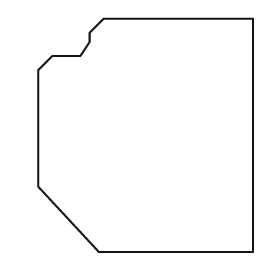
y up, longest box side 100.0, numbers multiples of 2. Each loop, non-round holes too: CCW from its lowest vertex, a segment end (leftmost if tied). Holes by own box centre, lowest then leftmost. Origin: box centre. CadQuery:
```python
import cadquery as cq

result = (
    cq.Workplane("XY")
    .moveTo(-20.0, -50.0)
    .lineTo(46.0, -50.0)
    .lineTo(46.0, 50.0)
    .lineTo(-18.0, 50.0)
    .lineTo(-24.0, 44.0)
    .lineTo(-24.0, 40.0)
    .lineTo(-28.0, 34.0)
    .lineTo(-40.0, 34.0)
    .lineTo(-46.0, 28.0)
    .lineTo(-46.0, -22.0)
    .close()
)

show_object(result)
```